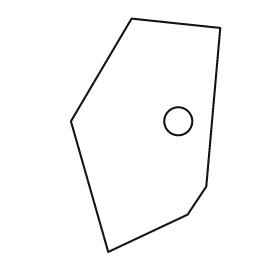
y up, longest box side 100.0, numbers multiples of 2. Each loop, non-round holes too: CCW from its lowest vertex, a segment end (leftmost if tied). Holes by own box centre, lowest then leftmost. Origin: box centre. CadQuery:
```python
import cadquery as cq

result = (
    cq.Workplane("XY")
    .moveTo(-16.0, -50.0)
    .lineTo(18.0, -34.0)
    .lineTo(26.0, -22.0)
    .lineTo(32.0, 46.0)
    .lineTo(-6.0, 50.0)
    .lineTo(-32.0, 6.0)
    .close()
    .moveTo(14.0, 6.0)
    .circle(6.0)
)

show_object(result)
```